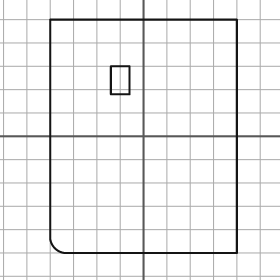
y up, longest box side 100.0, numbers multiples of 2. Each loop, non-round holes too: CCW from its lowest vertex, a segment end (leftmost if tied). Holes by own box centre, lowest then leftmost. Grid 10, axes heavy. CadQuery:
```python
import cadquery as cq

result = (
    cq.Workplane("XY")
    .moveTo(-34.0, -50.0)
    .lineTo(40.0, -50.0)
    .lineTo(40.0, 50.0)
    .lineTo(-40.0, 50.0)
    .lineTo(-40.0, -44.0)
    .threePointArc((-38.0, -48.0), (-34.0, -50.0))
    .close()
    .moveTo(-14.0, 18.0)
    .lineTo(-6.0, 18.0)
    .lineTo(-6.0, 30.0)
    .lineTo(-14.0, 30.0)
    .close()
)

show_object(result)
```